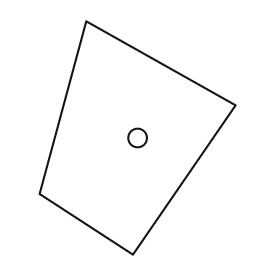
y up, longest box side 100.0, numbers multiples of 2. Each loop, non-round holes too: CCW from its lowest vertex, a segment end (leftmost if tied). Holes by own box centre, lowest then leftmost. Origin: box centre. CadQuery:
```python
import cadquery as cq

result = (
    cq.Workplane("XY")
    .moveTo(-2.0, -50.0)
    .lineTo(42.0, 14.0)
    .lineTo(-22.0, 50.0)
    .lineTo(-42.0, -24.0)
    .close()
    .moveTo(0.0, 0.0)
    .circle(4.0)
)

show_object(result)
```